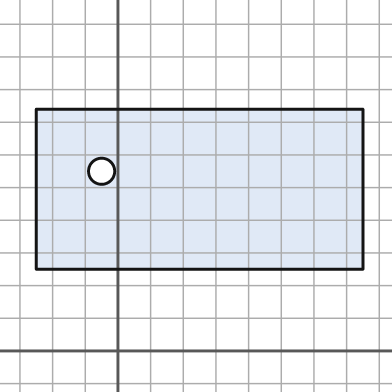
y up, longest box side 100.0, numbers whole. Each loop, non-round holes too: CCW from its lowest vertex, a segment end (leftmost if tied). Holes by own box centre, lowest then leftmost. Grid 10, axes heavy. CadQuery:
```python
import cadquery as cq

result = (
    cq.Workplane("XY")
    .moveTo(-25.0, 25.0)
    .lineTo(75.0, 25.0)
    .lineTo(75.0, 74.0)
    .lineTo(-25.0, 74.0)
    .close()
    .moveTo(-5.0, 55.0)
    .circle(4.0)
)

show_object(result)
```